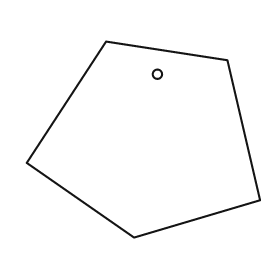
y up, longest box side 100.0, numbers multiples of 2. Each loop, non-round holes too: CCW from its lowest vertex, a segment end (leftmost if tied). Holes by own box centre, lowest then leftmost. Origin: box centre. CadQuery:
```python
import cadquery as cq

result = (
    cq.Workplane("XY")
    .moveTo(-4.0, -42.0)
    .lineTo(50.0, -26.0)
    .lineTo(36.0, 34.0)
    .lineTo(-16.0, 42.0)
    .lineTo(-50.0, -10.0)
    .close()
    .moveTo(6.0, 28.0)
    .circle(2.0)
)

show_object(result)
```